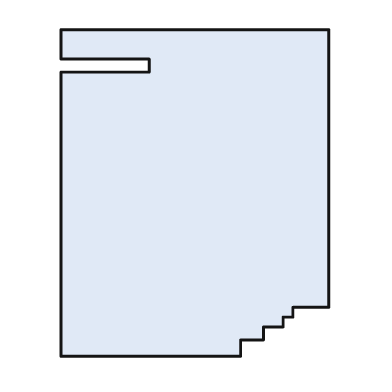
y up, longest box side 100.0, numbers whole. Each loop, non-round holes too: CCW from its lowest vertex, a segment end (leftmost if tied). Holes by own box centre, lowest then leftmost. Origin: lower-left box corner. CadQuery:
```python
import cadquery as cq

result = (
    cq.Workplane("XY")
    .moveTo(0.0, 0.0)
    .lineTo(55.0, 0.0)
    .lineTo(55.0, 5.0)
    .lineTo(62.0, 5.0)
    .lineTo(62.0, 9.0)
    .lineTo(68.0, 9.0)
    .lineTo(68.0, 12.0)
    .lineTo(71.0, 12.0)
    .lineTo(71.0, 15.0)
    .lineTo(82.0, 15.0)
    .lineTo(82.0, 100.0)
    .lineTo(0.0, 100.0)
    .lineTo(0.0, 91.0)
    .lineTo(27.0, 91.0)
    .lineTo(27.0, 87.0)
    .lineTo(0.0, 87.0)
    .close()
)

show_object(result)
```